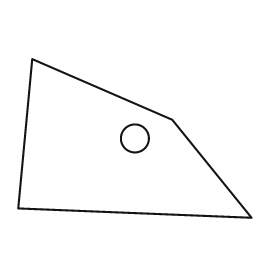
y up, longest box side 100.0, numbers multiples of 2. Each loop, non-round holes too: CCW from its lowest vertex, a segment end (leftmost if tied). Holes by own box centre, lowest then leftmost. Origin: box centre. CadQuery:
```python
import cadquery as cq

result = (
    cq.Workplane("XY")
    .moveTo(50.0, -34.0)
    .lineTo(16.0, 8.0)
    .lineTo(-44.0, 34.0)
    .lineTo(-50.0, -30.0)
    .close()
    .moveTo(0.0, 0.0)
    .circle(6.0)
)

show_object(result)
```